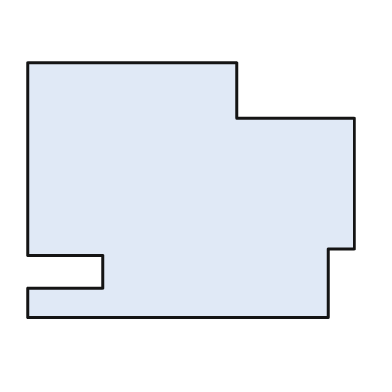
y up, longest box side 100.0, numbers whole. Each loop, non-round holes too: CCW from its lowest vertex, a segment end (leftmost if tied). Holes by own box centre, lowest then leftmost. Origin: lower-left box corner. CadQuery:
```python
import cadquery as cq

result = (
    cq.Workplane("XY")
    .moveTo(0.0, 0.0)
    .lineTo(92.0, 0.0)
    .lineTo(92.0, 21.0)
    .lineTo(100.0, 21.0)
    .lineTo(100.0, 61.0)
    .lineTo(64.0, 61.0)
    .lineTo(64.0, 78.0)
    .lineTo(0.0, 78.0)
    .lineTo(0.0, 19.0)
    .lineTo(23.0, 19.0)
    .lineTo(23.0, 9.0)
    .lineTo(0.0, 9.0)
    .close()
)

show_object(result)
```